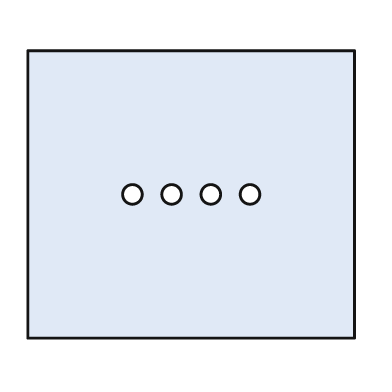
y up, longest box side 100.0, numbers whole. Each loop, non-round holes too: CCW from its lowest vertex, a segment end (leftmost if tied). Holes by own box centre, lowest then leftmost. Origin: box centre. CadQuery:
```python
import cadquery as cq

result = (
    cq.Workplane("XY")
    .moveTo(-50.0, -44.0)
    .lineTo(50.0, -44.0)
    .lineTo(50.0, 44.0)
    .lineTo(-50.0, 44.0)
    .close()
    .moveTo(-18.0, 0.0)
    .circle(3.0)
    .moveTo(-6.0, 0.0)
    .circle(3.0)
    .moveTo(6.0, 0.0)
    .circle(3.0)
    .moveTo(18.0, 0.0)
    .circle(3.0)
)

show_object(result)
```